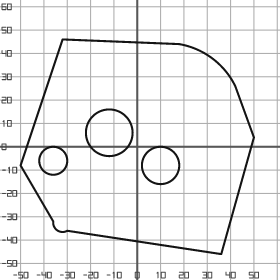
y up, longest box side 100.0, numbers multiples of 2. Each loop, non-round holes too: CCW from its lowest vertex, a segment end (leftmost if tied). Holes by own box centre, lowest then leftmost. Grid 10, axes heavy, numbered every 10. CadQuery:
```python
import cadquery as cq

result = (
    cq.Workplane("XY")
    .moveTo(36.0, -46.0)
    .lineTo(50.0, 4.0)
    .lineTo(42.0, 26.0)
    .threePointArc((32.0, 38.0), (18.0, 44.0))
    .lineTo(-32.0, 46.0)
    .lineTo(-50.0, -8.0)
    .lineTo(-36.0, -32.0)
    .threePointArc((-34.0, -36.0), (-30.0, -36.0))
    .close()
    .moveTo(10.0, -8.0)
    .circle(8.0)
    .moveTo(-36.0, -6.0)
    .circle(6.0)
    .moveTo(-12.0, 6.0)
    .circle(10.0)
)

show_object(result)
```